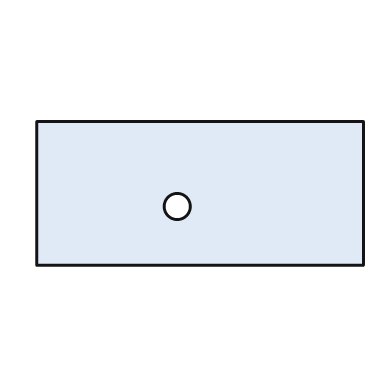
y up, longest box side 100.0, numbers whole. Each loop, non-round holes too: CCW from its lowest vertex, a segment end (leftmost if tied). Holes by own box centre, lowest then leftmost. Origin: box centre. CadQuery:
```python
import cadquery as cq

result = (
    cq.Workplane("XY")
    .moveTo(-50.0, -22.0)
    .lineTo(50.0, -22.0)
    .lineTo(50.0, 22.0)
    .lineTo(-50.0, 22.0)
    .close()
    .moveTo(-7.0, -4.0)
    .circle(4.0)
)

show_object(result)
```